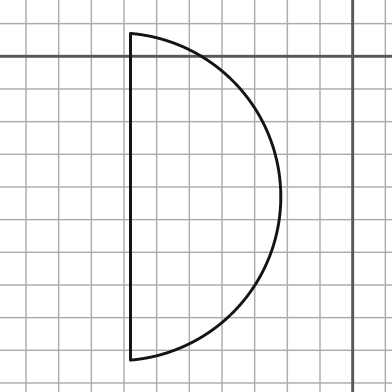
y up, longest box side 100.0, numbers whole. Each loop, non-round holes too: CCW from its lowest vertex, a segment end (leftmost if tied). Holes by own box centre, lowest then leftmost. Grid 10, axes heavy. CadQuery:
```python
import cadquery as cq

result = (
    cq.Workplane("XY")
    .moveTo(-68.0, -93.0)
    .threePointArc((-22.0, -43.0), (-68.0, 7.0))
    .close()
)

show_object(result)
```